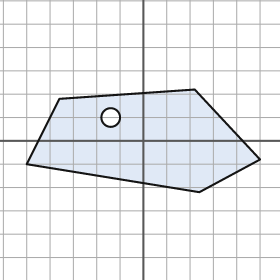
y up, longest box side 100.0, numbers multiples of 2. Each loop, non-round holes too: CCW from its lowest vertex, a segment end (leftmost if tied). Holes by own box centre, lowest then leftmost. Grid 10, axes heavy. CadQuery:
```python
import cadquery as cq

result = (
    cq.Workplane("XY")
    .moveTo(24.0, -22.0)
    .lineTo(50.0, -8.0)
    .lineTo(22.0, 22.0)
    .lineTo(-36.0, 18.0)
    .lineTo(-50.0, -10.0)
    .close()
    .moveTo(-14.0, 10.0)
    .circle(4.0)
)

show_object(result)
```